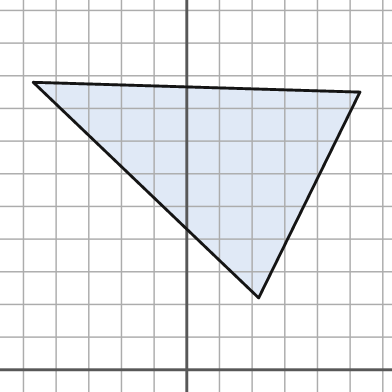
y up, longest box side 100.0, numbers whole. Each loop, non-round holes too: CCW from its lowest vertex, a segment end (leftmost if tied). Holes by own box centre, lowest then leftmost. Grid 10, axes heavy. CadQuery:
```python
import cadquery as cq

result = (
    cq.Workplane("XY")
    .moveTo(22.0, 22.0)
    .lineTo(53.0, 85.0)
    .lineTo(-47.0, 88.0)
    .close()
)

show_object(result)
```